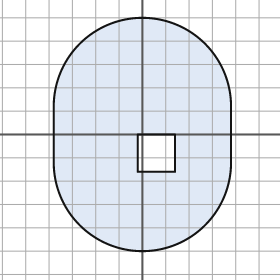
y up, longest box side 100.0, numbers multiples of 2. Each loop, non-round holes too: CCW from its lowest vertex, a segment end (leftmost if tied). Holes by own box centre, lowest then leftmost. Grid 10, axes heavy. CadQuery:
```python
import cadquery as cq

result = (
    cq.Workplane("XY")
    .moveTo(-38.0, -12.0)
    .threePointArc((0.0, -50.0), (38.0, -12.0))
    .lineTo(38.0, 12.0)
    .threePointArc((0.0, 50.0), (-38.0, 12.0))
    .close()
    .moveTo(-2.0, -16.0)
    .lineTo(14.0, -16.0)
    .lineTo(14.0, 0.0)
    .lineTo(-2.0, 0.0)
    .close()
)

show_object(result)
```